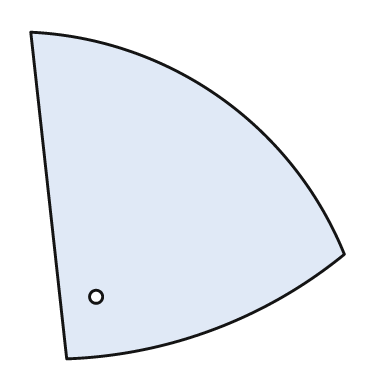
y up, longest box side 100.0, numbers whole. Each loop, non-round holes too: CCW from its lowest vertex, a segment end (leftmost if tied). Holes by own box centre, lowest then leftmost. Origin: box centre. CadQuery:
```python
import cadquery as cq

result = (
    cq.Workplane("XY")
    .moveTo(-37.0, -50.0)
    .threePointArc((8.0, -41.0), (48.0, -18.0))
    .threePointArc((10.0, 30.0), (-48.0, 50.0))
    .close()
    .moveTo(-28.0, -31.0)
    .circle(2.0)
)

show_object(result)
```